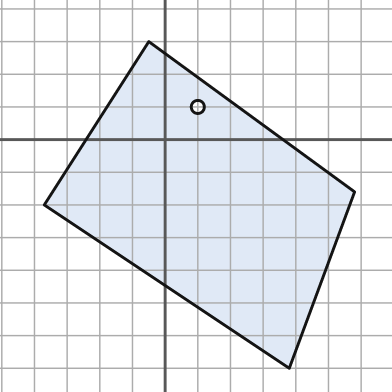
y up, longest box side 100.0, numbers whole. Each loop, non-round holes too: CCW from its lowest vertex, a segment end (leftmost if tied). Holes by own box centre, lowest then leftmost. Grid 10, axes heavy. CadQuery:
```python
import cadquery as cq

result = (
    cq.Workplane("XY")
    .moveTo(38.0, -70.0)
    .lineTo(58.0, -16.0)
    .lineTo(-5.0, 30.0)
    .lineTo(-37.0, -20.0)
    .close()
    .moveTo(10.0, 10.0)
    .circle(2.0)
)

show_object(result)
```